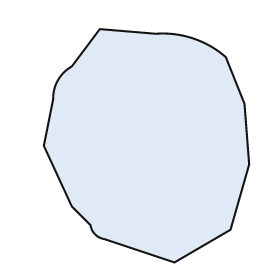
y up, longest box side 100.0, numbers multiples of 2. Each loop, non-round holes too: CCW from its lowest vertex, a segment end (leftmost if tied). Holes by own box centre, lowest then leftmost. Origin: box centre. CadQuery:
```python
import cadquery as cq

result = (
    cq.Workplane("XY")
    .moveTo(12.0, -50.0)
    .lineTo(36.0, -36.0)
    .lineTo(44.0, -8.0)
    .lineTo(42.0, 18.0)
    .lineTo(34.0, 38.0)
    .threePointArc((20.0, 46.0), (4.0, 48.0))
    .lineTo(-20.0, 50.0)
    .lineTo(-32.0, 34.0)
    .threePointArc((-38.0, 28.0), (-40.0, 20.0))
    .lineTo(-44.0, 0.0)
    .lineTo(-32.0, -26.0)
    .lineTo(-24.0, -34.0)
    .threePointArc((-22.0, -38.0), (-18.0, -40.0))
    .close()
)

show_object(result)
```